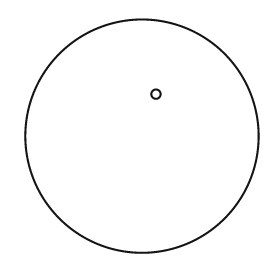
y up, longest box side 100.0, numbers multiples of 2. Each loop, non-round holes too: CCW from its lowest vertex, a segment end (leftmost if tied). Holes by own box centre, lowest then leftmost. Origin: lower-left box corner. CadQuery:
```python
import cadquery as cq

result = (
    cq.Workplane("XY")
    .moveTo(50.0, 50.0)
    .circle(50.0)
    .moveTo(56.0, 68.0)
    .circle(2.0)
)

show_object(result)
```